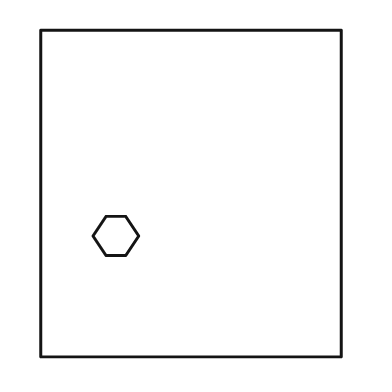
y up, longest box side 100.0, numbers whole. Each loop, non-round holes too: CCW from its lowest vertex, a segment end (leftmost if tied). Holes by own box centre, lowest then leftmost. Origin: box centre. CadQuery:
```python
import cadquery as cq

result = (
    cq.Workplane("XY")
    .moveTo(-46.0, -50.0)
    .lineTo(46.0, -50.0)
    .lineTo(46.0, 50.0)
    .lineTo(-46.0, 50.0)
    .close()
    .moveTo(-26.0, -19.0)
    .lineTo(-20.0, -19.0)
    .lineTo(-16.0, -13.0)
    .lineTo(-20.0, -7.0)
    .lineTo(-26.0, -7.0)
    .lineTo(-30.0, -13.0)
    .close()
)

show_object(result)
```